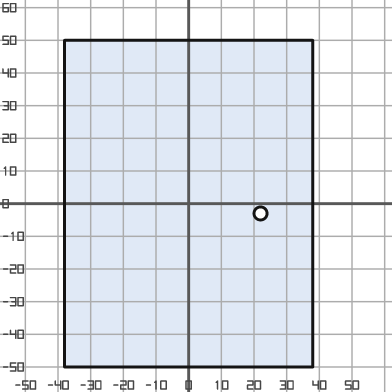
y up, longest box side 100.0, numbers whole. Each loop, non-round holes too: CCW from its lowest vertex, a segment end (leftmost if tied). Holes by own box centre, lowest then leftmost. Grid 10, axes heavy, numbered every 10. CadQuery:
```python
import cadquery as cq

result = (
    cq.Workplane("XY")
    .moveTo(-38.0, -50.0)
    .lineTo(38.0, -50.0)
    .lineTo(38.0, 50.0)
    .lineTo(-38.0, 50.0)
    .close()
    .moveTo(22.0, -3.0)
    .circle(2.0)
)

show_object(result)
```